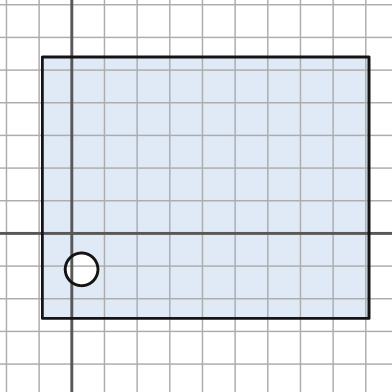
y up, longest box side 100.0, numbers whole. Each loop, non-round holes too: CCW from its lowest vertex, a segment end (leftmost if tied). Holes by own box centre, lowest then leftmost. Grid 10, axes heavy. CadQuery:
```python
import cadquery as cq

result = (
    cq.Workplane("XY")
    .moveTo(-9.0, -26.0)
    .lineTo(91.0, -26.0)
    .lineTo(91.0, 54.0)
    .lineTo(-9.0, 54.0)
    .close()
    .moveTo(3.0, -11.0)
    .circle(5.0)
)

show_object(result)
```